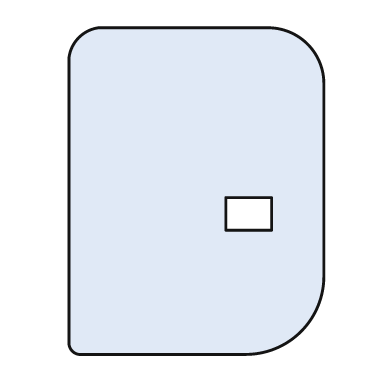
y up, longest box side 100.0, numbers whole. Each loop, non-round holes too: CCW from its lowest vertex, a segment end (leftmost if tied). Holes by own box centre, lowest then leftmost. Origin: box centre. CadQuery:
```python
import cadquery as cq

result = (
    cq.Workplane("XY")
    .moveTo(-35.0, -50.0)
    .lineTo(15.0, -50.0)
    .threePointArc((32.0, -43.0), (39.0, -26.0))
    .lineTo(39.0, 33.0)
    .threePointArc((34.0, 45.0), (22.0, 50.0))
    .lineTo(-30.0, 50.0)
    .threePointArc((-36.0, 47.0), (-39.0, 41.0))
    .lineTo(-39.0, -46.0)
    .threePointArc((-38.0, -49.0), (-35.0, -50.0))
    .close()
    .moveTo(9.0, -12.0)
    .lineTo(23.0, -12.0)
    .lineTo(23.0, -2.0)
    .lineTo(9.0, -2.0)
    .close()
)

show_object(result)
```